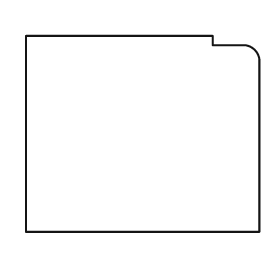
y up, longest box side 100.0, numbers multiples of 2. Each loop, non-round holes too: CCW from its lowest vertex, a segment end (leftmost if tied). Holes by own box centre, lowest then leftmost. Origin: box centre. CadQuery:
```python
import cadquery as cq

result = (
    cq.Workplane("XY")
    .moveTo(-50.0, -42.0)
    .lineTo(50.0, -42.0)
    .lineTo(50.0, 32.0)
    .threePointArc((48.0, 36.0), (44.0, 38.0))
    .lineTo(30.0, 38.0)
    .lineTo(30.0, 42.0)
    .lineTo(-50.0, 42.0)
    .close()
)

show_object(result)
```